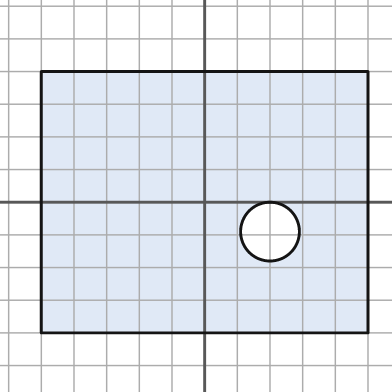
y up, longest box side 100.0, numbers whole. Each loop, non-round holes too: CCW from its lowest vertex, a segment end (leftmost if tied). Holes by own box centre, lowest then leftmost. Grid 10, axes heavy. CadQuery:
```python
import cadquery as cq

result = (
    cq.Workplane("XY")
    .moveTo(-50.0, -40.0)
    .lineTo(50.0, -40.0)
    .lineTo(50.0, 40.0)
    .lineTo(-50.0, 40.0)
    .close()
    .moveTo(20.0, -9.0)
    .circle(9.0)
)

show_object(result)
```